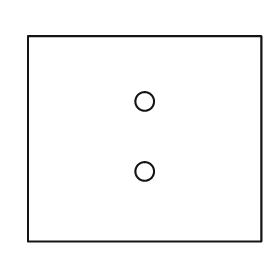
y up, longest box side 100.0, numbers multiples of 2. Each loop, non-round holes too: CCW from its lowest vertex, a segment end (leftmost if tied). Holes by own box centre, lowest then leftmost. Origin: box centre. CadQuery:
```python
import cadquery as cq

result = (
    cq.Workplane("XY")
    .moveTo(-50.0, -44.0)
    .lineTo(50.0, -44.0)
    .lineTo(50.0, 44.0)
    .lineTo(-50.0, 44.0)
    .close()
    .moveTo(0.0, -14.0)
    .circle(4.0)
    .moveTo(0.0, 16.0)
    .circle(4.0)
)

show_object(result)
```